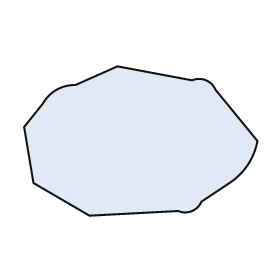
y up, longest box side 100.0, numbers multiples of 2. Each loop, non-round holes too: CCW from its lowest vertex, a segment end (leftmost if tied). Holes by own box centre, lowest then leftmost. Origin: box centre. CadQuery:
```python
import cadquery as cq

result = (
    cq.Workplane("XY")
    .moveTo(-22.0, -32.0)
    .lineTo(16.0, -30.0)
    .threePointArc((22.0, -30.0), (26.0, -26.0))
    .lineTo(38.0, -18.0)
    .threePointArc((46.0, -10.0), (50.0, 0.0))
    .lineTo(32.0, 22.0)
    .threePointArc((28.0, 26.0), (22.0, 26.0))
    .lineTo(-10.0, 32.0)
    .lineTo(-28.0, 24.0)
    .threePointArc((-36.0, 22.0), (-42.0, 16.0))
    .lineTo(-50.0, 6.0)
    .lineTo(-46.0, -18.0)
    .close()
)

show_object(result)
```